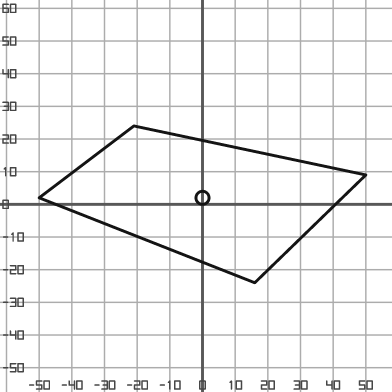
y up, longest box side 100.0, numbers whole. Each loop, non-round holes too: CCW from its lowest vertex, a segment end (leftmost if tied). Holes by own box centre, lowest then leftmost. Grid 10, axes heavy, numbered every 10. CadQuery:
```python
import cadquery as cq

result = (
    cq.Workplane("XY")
    .moveTo(16.0, -24.0)
    .lineTo(50.0, 9.0)
    .lineTo(-21.0, 24.0)
    .lineTo(-50.0, 2.0)
    .close()
    .moveTo(0.0, 2.0)
    .circle(2.0)
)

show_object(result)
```